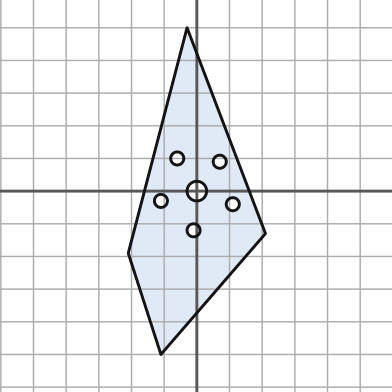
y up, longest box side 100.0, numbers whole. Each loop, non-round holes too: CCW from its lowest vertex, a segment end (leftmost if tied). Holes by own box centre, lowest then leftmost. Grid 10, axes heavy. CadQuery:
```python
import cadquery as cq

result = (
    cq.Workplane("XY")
    .moveTo(-11.0, -50.0)
    .lineTo(21.0, -13.0)
    .lineTo(-3.0, 50.0)
    .lineTo(-21.0, -19.0)
    .close()
    .moveTo(-1.0, -12.0)
    .circle(2.0)
    .moveTo(11.0, -4.0)
    .circle(2.0)
    .moveTo(-11.0, -3.0)
    .circle(2.0)
    .moveTo(0.0, 0.0)
    .circle(3.0)
    .moveTo(7.0, 9.0)
    .circle(2.0)
    .moveTo(-6.0, 10.0)
    .circle(2.0)
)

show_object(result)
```